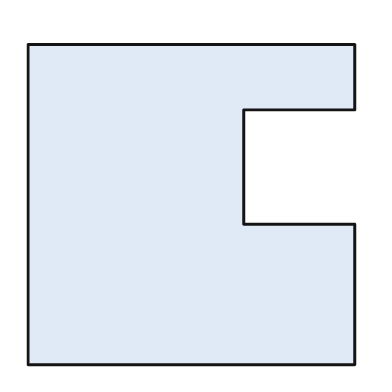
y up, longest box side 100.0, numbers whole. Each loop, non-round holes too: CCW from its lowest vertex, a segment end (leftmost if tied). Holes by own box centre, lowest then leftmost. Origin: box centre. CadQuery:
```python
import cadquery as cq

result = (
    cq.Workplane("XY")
    .moveTo(-50.0, -49.0)
    .lineTo(50.0, -49.0)
    .lineTo(50.0, -6.0)
    .lineTo(16.0, -6.0)
    .lineTo(16.0, 29.0)
    .lineTo(50.0, 29.0)
    .lineTo(50.0, 49.0)
    .lineTo(-50.0, 49.0)
    .close()
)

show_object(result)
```